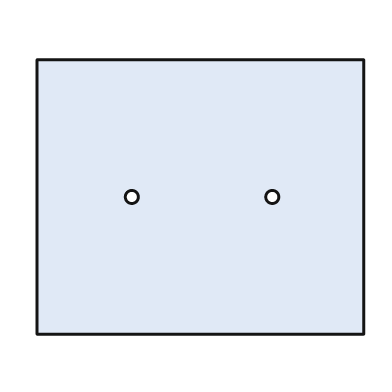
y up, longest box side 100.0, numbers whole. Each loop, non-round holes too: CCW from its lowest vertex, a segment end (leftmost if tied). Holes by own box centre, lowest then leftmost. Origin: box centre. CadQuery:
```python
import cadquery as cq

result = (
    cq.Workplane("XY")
    .moveTo(-50.0, -42.0)
    .lineTo(50.0, -42.0)
    .lineTo(50.0, 42.0)
    .lineTo(-50.0, 42.0)
    .close()
    .moveTo(-21.0, 0.0)
    .circle(2.0)
    .moveTo(22.0, 0.0)
    .circle(2.0)
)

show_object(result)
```